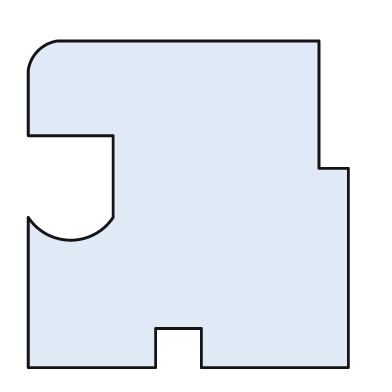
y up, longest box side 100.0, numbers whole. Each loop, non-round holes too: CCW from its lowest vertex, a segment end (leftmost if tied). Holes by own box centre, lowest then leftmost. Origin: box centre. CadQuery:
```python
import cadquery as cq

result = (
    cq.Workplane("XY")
    .moveTo(-49.0, -50.0)
    .lineTo(-10.0, -50.0)
    .lineTo(-10.0, -38.0)
    .lineTo(4.0, -38.0)
    .lineTo(4.0, -50.0)
    .lineTo(49.0, -50.0)
    .lineTo(49.0, 11.0)
    .lineTo(40.0, 11.0)
    .lineTo(40.0, 50.0)
    .lineTo(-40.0, 50.0)
    .threePointArc((-46.0, 47.0), (-49.0, 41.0))
    .lineTo(-49.0, 21.0)
    .lineTo(-23.0, 21.0)
    .lineTo(-23.0, -4.0)
    .threePointArc((-36.0, -11.0), (-49.0, -4.0))
    .close()
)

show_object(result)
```